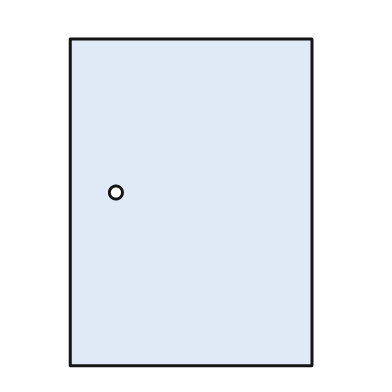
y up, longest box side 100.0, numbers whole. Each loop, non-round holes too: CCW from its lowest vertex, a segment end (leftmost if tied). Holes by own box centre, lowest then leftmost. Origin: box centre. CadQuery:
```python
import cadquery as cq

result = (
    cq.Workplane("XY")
    .moveTo(-37.0, -50.0)
    .lineTo(37.0, -50.0)
    .lineTo(37.0, 50.0)
    .lineTo(-37.0, 50.0)
    .close()
    .moveTo(-23.0, 3.0)
    .circle(2.0)
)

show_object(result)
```